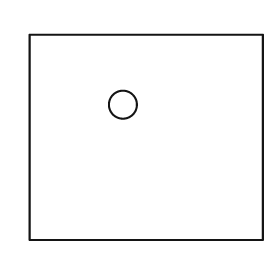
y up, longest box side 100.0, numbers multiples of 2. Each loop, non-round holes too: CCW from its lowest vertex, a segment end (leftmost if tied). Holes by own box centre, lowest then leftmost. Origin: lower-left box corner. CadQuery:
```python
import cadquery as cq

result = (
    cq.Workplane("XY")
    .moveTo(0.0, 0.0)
    .lineTo(100.0, 0.0)
    .lineTo(100.0, 88.0)
    .lineTo(0.0, 88.0)
    .close()
    .moveTo(40.0, 58.0)
    .circle(6.0)
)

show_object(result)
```